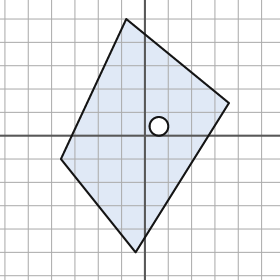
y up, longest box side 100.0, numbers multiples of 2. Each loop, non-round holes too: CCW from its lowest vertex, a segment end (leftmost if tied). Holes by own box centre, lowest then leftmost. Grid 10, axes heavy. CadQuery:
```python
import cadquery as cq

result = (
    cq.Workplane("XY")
    .moveTo(-4.0, -50.0)
    .lineTo(36.0, 14.0)
    .lineTo(-8.0, 50.0)
    .lineTo(-36.0, -10.0)
    .close()
    .moveTo(6.0, 4.0)
    .circle(4.0)
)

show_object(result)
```